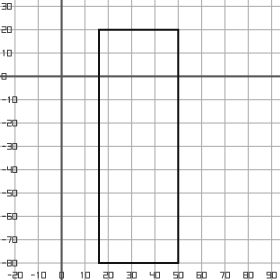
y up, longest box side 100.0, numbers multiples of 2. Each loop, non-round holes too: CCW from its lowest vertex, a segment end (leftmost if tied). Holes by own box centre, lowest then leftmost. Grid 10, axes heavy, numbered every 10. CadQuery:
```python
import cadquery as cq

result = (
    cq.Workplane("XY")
    .moveTo(16.0, -80.0)
    .lineTo(50.0, -80.0)
    .lineTo(50.0, 20.0)
    .lineTo(16.0, 20.0)
    .close()
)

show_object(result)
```